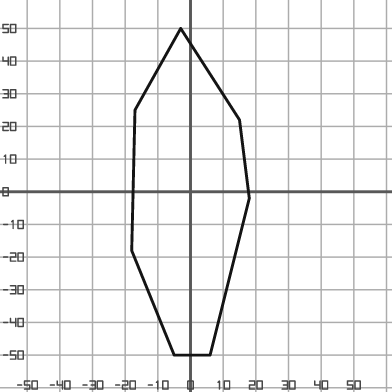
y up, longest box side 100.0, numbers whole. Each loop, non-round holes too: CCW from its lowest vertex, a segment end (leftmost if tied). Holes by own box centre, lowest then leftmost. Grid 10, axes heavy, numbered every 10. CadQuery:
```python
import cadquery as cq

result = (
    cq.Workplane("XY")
    .moveTo(-5.0, -50.0)
    .lineTo(6.0, -50.0)
    .lineTo(18.0, -2.0)
    .lineTo(15.0, 22.0)
    .lineTo(-3.0, 50.0)
    .lineTo(-17.0, 25.0)
    .lineTo(-18.0, -18.0)
    .close()
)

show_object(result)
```